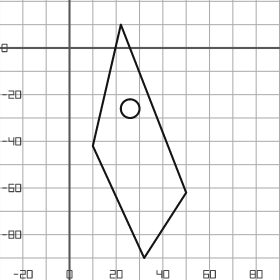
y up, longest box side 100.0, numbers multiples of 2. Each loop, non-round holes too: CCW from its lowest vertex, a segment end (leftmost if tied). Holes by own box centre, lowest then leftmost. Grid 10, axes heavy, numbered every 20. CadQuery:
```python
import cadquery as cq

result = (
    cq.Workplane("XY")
    .moveTo(32.0, -90.0)
    .lineTo(50.0, -62.0)
    .lineTo(22.0, 10.0)
    .lineTo(10.0, -42.0)
    .close()
    .moveTo(26.0, -26.0)
    .circle(4.0)
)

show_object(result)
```